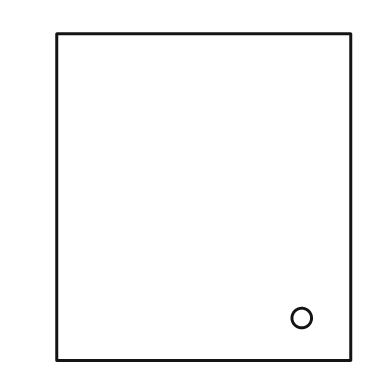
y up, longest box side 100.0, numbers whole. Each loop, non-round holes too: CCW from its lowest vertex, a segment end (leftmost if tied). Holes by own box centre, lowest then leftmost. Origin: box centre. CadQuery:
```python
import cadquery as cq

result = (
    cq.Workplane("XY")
    .moveTo(-45.0, -50.0)
    .lineTo(45.0, -50.0)
    .lineTo(45.0, 50.0)
    .lineTo(-45.0, 50.0)
    .close()
    .moveTo(30.0, -37.0)
    .circle(3.0)
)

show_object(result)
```